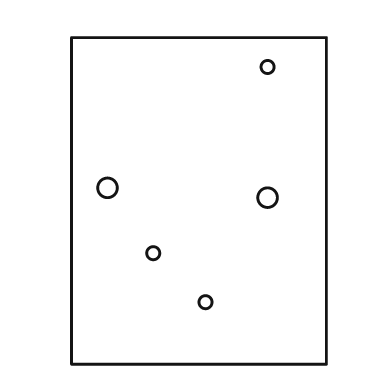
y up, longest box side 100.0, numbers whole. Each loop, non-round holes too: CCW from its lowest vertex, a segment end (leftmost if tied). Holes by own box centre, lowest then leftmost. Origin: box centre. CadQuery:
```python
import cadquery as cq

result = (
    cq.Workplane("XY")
    .moveTo(-39.0, -50.0)
    .lineTo(39.0, -50.0)
    .lineTo(39.0, 50.0)
    .lineTo(-39.0, 50.0)
    .close()
    .moveTo(2.0, -31.0)
    .circle(2.0)
    .moveTo(-14.0, -16.0)
    .circle(2.0)
    .moveTo(21.0, 1.0)
    .circle(3.0)
    .moveTo(-28.0, 4.0)
    .circle(3.0)
    .moveTo(21.0, 41.0)
    .circle(2.0)
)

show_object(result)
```